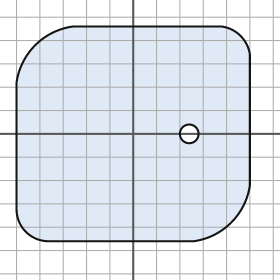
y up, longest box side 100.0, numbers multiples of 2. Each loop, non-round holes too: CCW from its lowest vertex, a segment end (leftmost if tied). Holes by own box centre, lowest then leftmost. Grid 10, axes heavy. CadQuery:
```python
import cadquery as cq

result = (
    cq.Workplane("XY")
    .moveTo(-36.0, -46.0)
    .lineTo(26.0, -46.0)
    .threePointArc((42.0, -38.0), (50.0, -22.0))
    .lineTo(50.0, 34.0)
    .threePointArc((46.0, 42.0), (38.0, 46.0))
    .lineTo(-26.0, 46.0)
    .threePointArc((-42.0, 38.0), (-50.0, 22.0))
    .lineTo(-50.0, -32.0)
    .threePointArc((-46.0, -42.0), (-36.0, -46.0))
    .close()
    .moveTo(24.0, 0.0)
    .circle(4.0)
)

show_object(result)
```